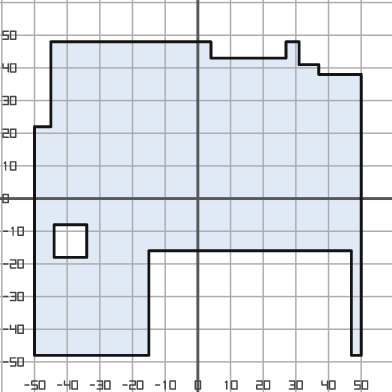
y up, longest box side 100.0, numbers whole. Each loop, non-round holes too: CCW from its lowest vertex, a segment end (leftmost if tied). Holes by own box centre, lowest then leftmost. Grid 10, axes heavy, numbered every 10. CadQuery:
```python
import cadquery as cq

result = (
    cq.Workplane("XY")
    .moveTo(-50.0, -48.0)
    .lineTo(-15.0, -48.0)
    .lineTo(-15.0, -16.0)
    .lineTo(47.0, -16.0)
    .lineTo(47.0, -48.0)
    .lineTo(50.0, -48.0)
    .lineTo(50.0, 38.0)
    .lineTo(37.0, 38.0)
    .lineTo(37.0, 41.0)
    .lineTo(31.0, 41.0)
    .lineTo(31.0, 48.0)
    .lineTo(27.0, 48.0)
    .lineTo(27.0, 43.0)
    .lineTo(4.0, 43.0)
    .lineTo(4.0, 48.0)
    .lineTo(-45.0, 48.0)
    .lineTo(-45.0, 22.0)
    .lineTo(-50.0, 22.0)
    .close()
    .moveTo(-44.0, -18.0)
    .lineTo(-34.0, -18.0)
    .lineTo(-34.0, -8.0)
    .lineTo(-44.0, -8.0)
    .close()
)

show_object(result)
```